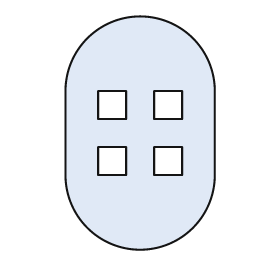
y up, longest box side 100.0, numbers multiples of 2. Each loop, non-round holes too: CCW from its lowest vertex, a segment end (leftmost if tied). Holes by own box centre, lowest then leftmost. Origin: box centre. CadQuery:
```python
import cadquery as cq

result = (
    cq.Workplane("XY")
    .moveTo(-32.0, -18.0)
    .threePointArc((0.0, -50.0), (32.0, -18.0))
    .lineTo(32.0, 18.0)
    .threePointArc((0.0, 50.0), (-32.0, 18.0))
    .close()
    .moveTo(-18.0, -18.0)
    .lineTo(-6.0, -18.0)
    .lineTo(-6.0, -6.0)
    .lineTo(-18.0, -6.0)
    .close()
    .moveTo(6.0, -18.0)
    .lineTo(18.0, -18.0)
    .lineTo(18.0, -6.0)
    .lineTo(6.0, -6.0)
    .close()
    .moveTo(-18.0, 6.0)
    .lineTo(-6.0, 6.0)
    .lineTo(-6.0, 18.0)
    .lineTo(-18.0, 18.0)
    .close()
    .moveTo(6.0, 6.0)
    .lineTo(18.0, 6.0)
    .lineTo(18.0, 18.0)
    .lineTo(6.0, 18.0)
    .close()
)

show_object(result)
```